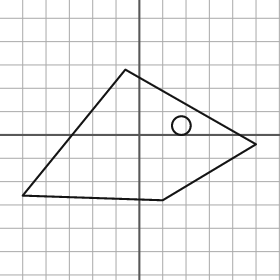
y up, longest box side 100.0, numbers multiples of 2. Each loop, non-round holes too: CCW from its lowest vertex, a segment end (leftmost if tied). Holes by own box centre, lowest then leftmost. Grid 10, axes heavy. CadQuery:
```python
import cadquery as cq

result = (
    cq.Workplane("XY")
    .moveTo(10.0, -28.0)
    .lineTo(50.0, -4.0)
    .lineTo(-6.0, 28.0)
    .lineTo(-50.0, -26.0)
    .close()
    .moveTo(18.0, 4.0)
    .circle(4.0)
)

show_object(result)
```